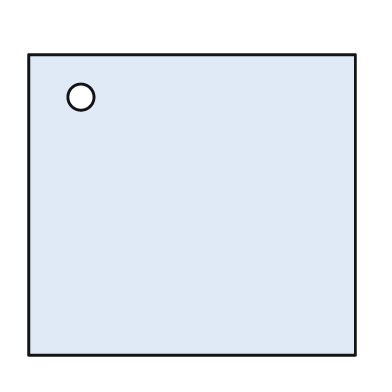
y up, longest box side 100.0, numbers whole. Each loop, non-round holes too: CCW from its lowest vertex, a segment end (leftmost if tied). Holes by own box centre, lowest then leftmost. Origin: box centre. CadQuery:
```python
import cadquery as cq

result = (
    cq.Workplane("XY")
    .moveTo(-50.0, -46.0)
    .lineTo(50.0, -46.0)
    .lineTo(50.0, 46.0)
    .lineTo(-50.0, 46.0)
    .close()
    .moveTo(-34.0, 33.0)
    .circle(4.0)
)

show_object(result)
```